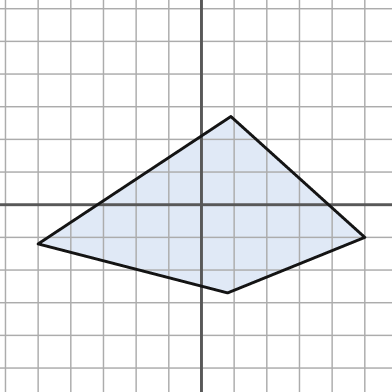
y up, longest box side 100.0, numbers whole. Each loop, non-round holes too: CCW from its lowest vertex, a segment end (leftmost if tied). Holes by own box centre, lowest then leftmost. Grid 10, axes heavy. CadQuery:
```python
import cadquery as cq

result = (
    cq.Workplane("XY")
    .moveTo(8.0, -27.0)
    .lineTo(50.0, -10.0)
    .lineTo(9.0, 27.0)
    .lineTo(-50.0, -12.0)
    .close()
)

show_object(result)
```